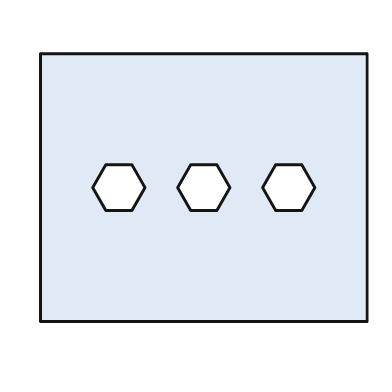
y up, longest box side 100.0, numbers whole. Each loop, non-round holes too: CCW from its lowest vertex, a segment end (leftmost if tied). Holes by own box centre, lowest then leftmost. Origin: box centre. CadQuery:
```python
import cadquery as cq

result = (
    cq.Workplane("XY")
    .moveTo(-50.0, -41.0)
    .lineTo(50.0, -41.0)
    .lineTo(50.0, 41.0)
    .lineTo(-50.0, 41.0)
    .close()
    .moveTo(-30.0, -7.0)
    .lineTo(-22.0, -7.0)
    .lineTo(-18.0, 0.0)
    .lineTo(-22.0, 7.0)
    .lineTo(-30.0, 7.0)
    .lineTo(-34.0, 0.0)
    .close()
    .moveTo(-4.0, -7.0)
    .lineTo(4.0, -7.0)
    .lineTo(8.0, 0.0)
    .lineTo(4.0, 7.0)
    .lineTo(-4.0, 7.0)
    .lineTo(-8.0, 0.0)
    .close()
    .moveTo(22.0, -7.0)
    .lineTo(30.0, -7.0)
    .lineTo(34.0, 0.0)
    .lineTo(30.0, 7.0)
    .lineTo(22.0, 7.0)
    .lineTo(18.0, 0.0)
    .close()
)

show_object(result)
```